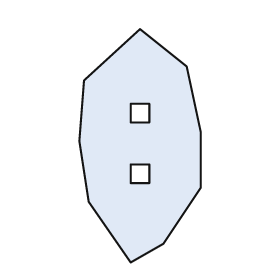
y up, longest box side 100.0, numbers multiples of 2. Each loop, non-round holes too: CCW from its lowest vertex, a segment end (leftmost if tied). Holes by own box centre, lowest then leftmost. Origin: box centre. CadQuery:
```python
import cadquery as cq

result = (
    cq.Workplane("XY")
    .moveTo(-4.0, -50.0)
    .lineTo(10.0, -42.0)
    .lineTo(26.0, -18.0)
    .lineTo(26.0, 6.0)
    .lineTo(20.0, 34.0)
    .lineTo(0.0, 50.0)
    .lineTo(-24.0, 28.0)
    .lineTo(-26.0, 2.0)
    .lineTo(-22.0, -24.0)
    .close()
    .moveTo(-4.0, -16.0)
    .lineTo(4.0, -16.0)
    .lineTo(4.0, -8.0)
    .lineTo(-4.0, -8.0)
    .close()
    .moveTo(-4.0, 10.0)
    .lineTo(4.0, 10.0)
    .lineTo(4.0, 18.0)
    .lineTo(-4.0, 18.0)
    .close()
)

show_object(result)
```